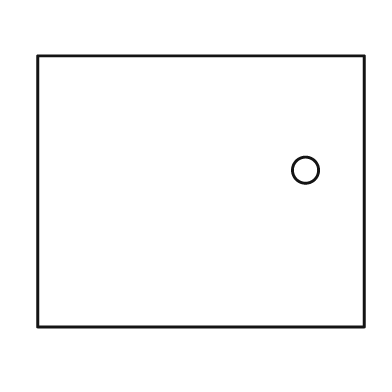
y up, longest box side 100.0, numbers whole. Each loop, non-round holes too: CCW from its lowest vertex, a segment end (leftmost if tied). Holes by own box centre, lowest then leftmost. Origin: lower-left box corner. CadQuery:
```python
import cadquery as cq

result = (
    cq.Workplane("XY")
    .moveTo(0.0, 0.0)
    .lineTo(100.0, 0.0)
    .lineTo(100.0, 83.0)
    .lineTo(0.0, 83.0)
    .close()
    .moveTo(82.0, 48.0)
    .circle(4.0)
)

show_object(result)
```